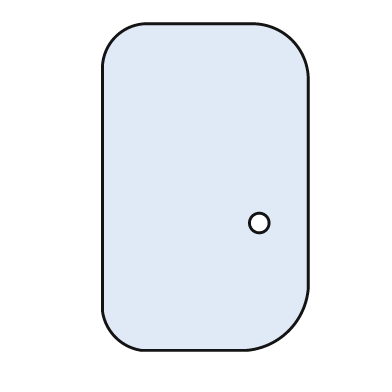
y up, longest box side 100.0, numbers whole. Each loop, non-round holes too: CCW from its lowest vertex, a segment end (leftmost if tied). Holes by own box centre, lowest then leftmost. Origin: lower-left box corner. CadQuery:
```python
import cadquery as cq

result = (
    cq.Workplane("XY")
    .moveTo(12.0, 0.0)
    .lineTo(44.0, 0.0)
    .threePointArc((57.0, 6.0), (63.0, 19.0))
    .lineTo(63.0, 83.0)
    .threePointArc((58.0, 95.0), (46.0, 100.0))
    .lineTo(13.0, 100.0)
    .threePointArc((4.0, 96.0), (0.0, 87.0))
    .lineTo(0.0, 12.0)
    .threePointArc((4.0, 4.0), (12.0, 0.0))
    .close()
    .moveTo(48.0, 39.0)
    .circle(3.0)
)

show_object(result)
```